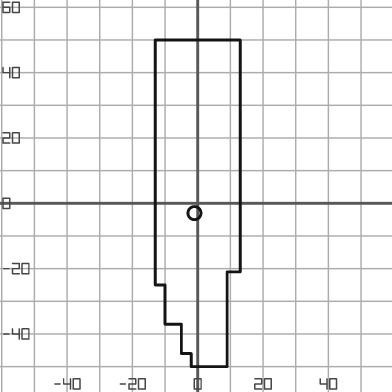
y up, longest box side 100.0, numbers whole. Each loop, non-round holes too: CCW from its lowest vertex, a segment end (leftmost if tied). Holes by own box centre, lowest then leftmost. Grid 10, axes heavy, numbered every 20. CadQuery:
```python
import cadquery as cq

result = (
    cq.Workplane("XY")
    .moveTo(-2.0, -50.0)
    .lineTo(9.0, -50.0)
    .lineTo(9.0, -21.0)
    .lineTo(13.0, -21.0)
    .lineTo(13.0, 50.0)
    .lineTo(-13.0, 50.0)
    .lineTo(-13.0, -25.0)
    .lineTo(-10.0, -25.0)
    .lineTo(-10.0, -37.0)
    .lineTo(-5.0, -37.0)
    .lineTo(-5.0, -46.0)
    .lineTo(-2.0, -46.0)
    .close()
    .moveTo(-1.0, -3.0)
    .circle(2.0)
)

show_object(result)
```